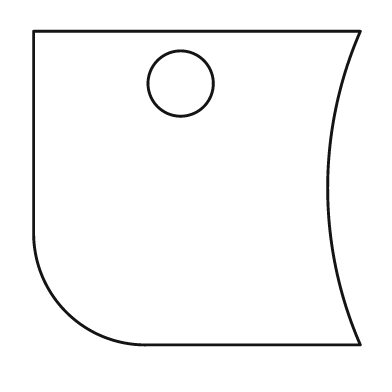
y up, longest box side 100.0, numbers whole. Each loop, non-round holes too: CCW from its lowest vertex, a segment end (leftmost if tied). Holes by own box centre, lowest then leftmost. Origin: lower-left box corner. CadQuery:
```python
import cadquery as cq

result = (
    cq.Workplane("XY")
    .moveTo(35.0, 0.0)
    .lineTo(100.0, 0.0)
    .threePointArc((90.0, 48.0), (100.0, 96.0))
    .lineTo(0.0, 96.0)
    .lineTo(0.0, 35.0)
    .threePointArc((10.0, 10.0), (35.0, 0.0))
    .close()
    .moveTo(45.0, 80.0)
    .circle(10.0)
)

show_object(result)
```